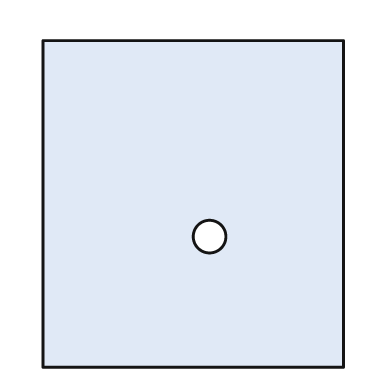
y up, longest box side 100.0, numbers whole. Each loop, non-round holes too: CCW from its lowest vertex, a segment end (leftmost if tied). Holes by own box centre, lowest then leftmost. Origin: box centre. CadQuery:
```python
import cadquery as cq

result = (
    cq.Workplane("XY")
    .moveTo(-46.0, -50.0)
    .lineTo(46.0, -50.0)
    .lineTo(46.0, 50.0)
    .lineTo(-46.0, 50.0)
    .close()
    .moveTo(5.0, -10.0)
    .circle(5.0)
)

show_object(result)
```